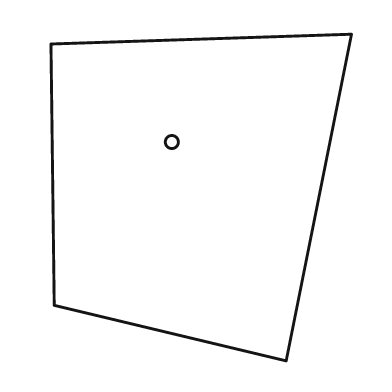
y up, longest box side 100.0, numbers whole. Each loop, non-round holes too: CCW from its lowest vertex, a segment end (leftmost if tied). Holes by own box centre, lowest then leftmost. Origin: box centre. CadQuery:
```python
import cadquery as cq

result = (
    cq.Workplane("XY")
    .moveTo(26.0, -50.0)
    .lineTo(46.0, 50.0)
    .lineTo(-46.0, 47.0)
    .lineTo(-45.0, -33.0)
    .close()
    .moveTo(-9.0, 17.0)
    .circle(2.0)
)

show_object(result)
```